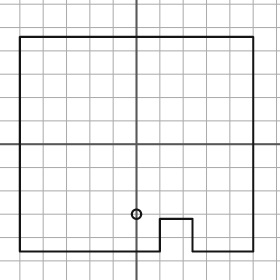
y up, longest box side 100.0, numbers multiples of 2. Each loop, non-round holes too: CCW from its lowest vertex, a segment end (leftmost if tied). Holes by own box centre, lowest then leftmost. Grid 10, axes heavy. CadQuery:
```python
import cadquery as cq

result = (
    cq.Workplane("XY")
    .moveTo(-50.0, -46.0)
    .lineTo(10.0, -46.0)
    .lineTo(10.0, -32.0)
    .lineTo(24.0, -32.0)
    .lineTo(24.0, -46.0)
    .lineTo(50.0, -46.0)
    .lineTo(50.0, 46.0)
    .lineTo(-50.0, 46.0)
    .close()
    .moveTo(0.0, -30.0)
    .circle(2.0)
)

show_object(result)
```